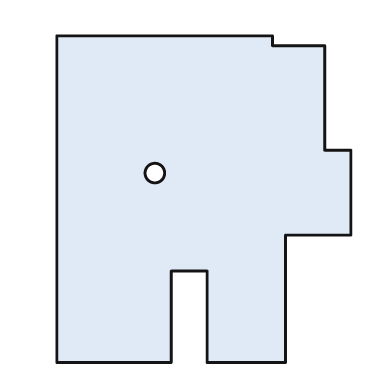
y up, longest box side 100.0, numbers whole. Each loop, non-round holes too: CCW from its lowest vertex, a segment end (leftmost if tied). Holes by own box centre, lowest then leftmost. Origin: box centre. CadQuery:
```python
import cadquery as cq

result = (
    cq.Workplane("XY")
    .moveTo(-45.0, -50.0)
    .lineTo(-10.0, -50.0)
    .lineTo(-10.0, -22.0)
    .lineTo(1.0, -22.0)
    .lineTo(1.0, -50.0)
    .lineTo(25.0, -50.0)
    .lineTo(25.0, -11.0)
    .lineTo(45.0, -11.0)
    .lineTo(45.0, 15.0)
    .lineTo(37.0, 15.0)
    .lineTo(37.0, 47.0)
    .lineTo(21.0, 47.0)
    .lineTo(21.0, 50.0)
    .lineTo(-45.0, 50.0)
    .close()
    .moveTo(-15.0, 8.0)
    .circle(3.0)
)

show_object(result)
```